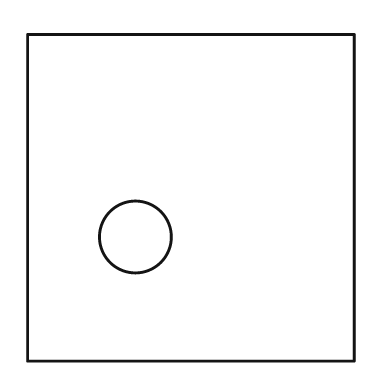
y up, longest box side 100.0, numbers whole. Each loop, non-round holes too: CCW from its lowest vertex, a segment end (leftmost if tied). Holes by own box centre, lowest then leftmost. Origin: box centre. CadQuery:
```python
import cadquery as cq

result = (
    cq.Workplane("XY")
    .moveTo(-50.0, -50.0)
    .lineTo(50.0, -50.0)
    .lineTo(50.0, 50.0)
    .lineTo(-50.0, 50.0)
    .close()
    .moveTo(-17.0, -12.0)
    .circle(11.0)
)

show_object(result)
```